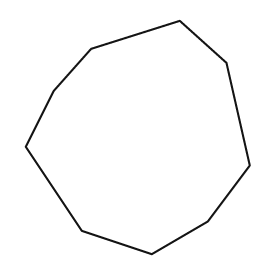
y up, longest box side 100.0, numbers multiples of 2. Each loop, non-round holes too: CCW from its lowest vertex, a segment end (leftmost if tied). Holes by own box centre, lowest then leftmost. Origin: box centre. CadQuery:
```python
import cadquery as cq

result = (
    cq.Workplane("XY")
    .moveTo(6.0, -50.0)
    .lineTo(30.0, -36.0)
    .lineTo(48.0, -12.0)
    .lineTo(38.0, 32.0)
    .lineTo(18.0, 50.0)
    .lineTo(-20.0, 38.0)
    .lineTo(-36.0, 20.0)
    .lineTo(-48.0, -4.0)
    .lineTo(-24.0, -40.0)
    .close()
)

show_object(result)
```